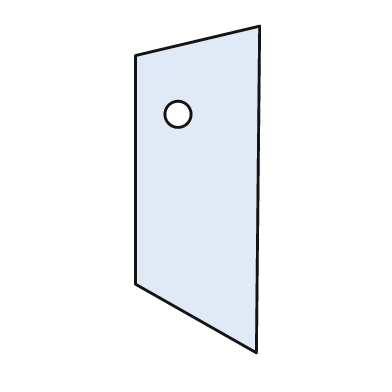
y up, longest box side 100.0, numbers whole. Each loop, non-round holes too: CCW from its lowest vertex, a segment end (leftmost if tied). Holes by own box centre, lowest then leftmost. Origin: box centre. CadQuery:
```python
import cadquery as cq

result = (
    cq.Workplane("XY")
    .moveTo(18.0, -50.0)
    .lineTo(19.0, 50.0)
    .lineTo(-19.0, 41.0)
    .lineTo(-19.0, -29.0)
    .close()
    .moveTo(-6.0, 23.0)
    .circle(4.0)
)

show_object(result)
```